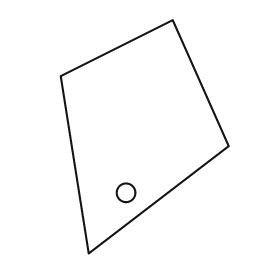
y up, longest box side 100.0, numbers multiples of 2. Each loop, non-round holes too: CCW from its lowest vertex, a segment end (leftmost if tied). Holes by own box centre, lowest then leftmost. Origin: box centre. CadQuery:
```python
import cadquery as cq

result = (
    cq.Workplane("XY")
    .moveTo(-24.0, -50.0)
    .lineTo(36.0, -4.0)
    .lineTo(12.0, 50.0)
    .lineTo(-36.0, 26.0)
    .close()
    .moveTo(-8.0, -24.0)
    .circle(4.0)
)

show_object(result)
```